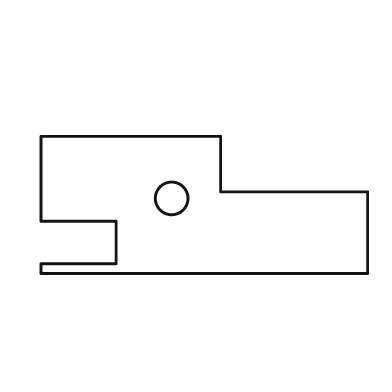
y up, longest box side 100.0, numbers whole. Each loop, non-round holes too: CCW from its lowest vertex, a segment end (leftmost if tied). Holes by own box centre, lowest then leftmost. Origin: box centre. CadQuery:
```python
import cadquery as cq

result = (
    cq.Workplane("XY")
    .moveTo(-50.0, -21.0)
    .lineTo(50.0, -21.0)
    .lineTo(50.0, 4.0)
    .lineTo(5.0, 4.0)
    .lineTo(5.0, 21.0)
    .lineTo(-50.0, 21.0)
    .lineTo(-50.0, -5.0)
    .lineTo(-27.0, -5.0)
    .lineTo(-27.0, -18.0)
    .lineTo(-50.0, -18.0)
    .close()
    .moveTo(-10.0, 2.0)
    .circle(5.0)
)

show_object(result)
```